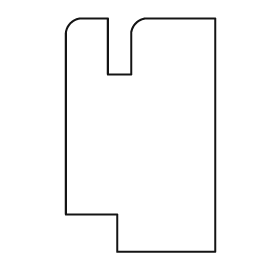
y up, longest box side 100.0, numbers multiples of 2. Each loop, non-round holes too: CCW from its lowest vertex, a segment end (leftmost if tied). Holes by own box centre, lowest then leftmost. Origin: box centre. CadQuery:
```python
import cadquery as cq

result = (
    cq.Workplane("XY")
    .moveTo(-10.0, -50.0)
    .lineTo(32.0, -50.0)
    .lineTo(32.0, 50.0)
    .lineTo(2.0, 50.0)
    .threePointArc((-2.0, 48.0), (-4.0, 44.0))
    .lineTo(-4.0, 26.0)
    .lineTo(-14.0, 26.0)
    .lineTo(-14.0, 50.0)
    .lineTo(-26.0, 50.0)
    .threePointArc((-30.0, 48.0), (-32.0, 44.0))
    .lineTo(-32.0, -34.0)
    .lineTo(-10.0, -34.0)
    .close()
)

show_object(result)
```